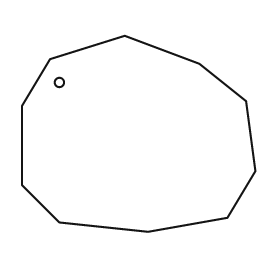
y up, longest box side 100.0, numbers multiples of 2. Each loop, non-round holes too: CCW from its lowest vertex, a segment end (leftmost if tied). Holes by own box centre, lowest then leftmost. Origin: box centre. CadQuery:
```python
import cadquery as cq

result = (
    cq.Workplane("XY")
    .moveTo(4.0, -42.0)
    .lineTo(38.0, -36.0)
    .lineTo(50.0, -16.0)
    .lineTo(46.0, 14.0)
    .lineTo(26.0, 30.0)
    .lineTo(-6.0, 42.0)
    .lineTo(-38.0, 32.0)
    .lineTo(-50.0, 12.0)
    .lineTo(-50.0, -22.0)
    .lineTo(-34.0, -38.0)
    .close()
    .moveTo(-34.0, 22.0)
    .circle(2.0)
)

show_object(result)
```